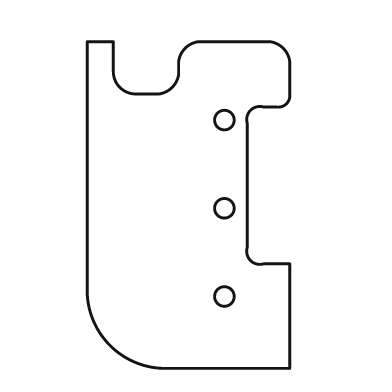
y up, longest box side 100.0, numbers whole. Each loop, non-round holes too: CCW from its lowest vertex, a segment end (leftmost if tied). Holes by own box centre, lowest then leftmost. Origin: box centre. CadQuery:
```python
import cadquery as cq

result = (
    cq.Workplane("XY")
    .moveTo(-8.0, -50.0)
    .lineTo(31.0, -50.0)
    .lineTo(31.0, -18.0)
    .lineTo(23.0, -18.0)
    .threePointArc((19.0, -17.0), (18.0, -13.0))
    .lineTo(18.0, 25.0)
    .threePointArc((19.0, 29.0), (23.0, 30.0))
    .lineTo(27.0, 30.0)
    .threePointArc((30.0, 31.0), (31.0, 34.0))
    .lineTo(31.0, 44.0)
    .threePointArc((29.0, 48.0), (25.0, 50.0))
    .lineTo(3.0, 50.0)
    .threePointArc((-1.0, 48.0), (-3.0, 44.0))
    .lineTo(-3.0, 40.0)
    .threePointArc((-5.0, 36.0), (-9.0, 34.0))
    .lineTo(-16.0, 34.0)
    .threePointArc((-21.0, 36.0), (-23.0, 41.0))
    .lineTo(-23.0, 50.0)
    .lineTo(-31.0, 50.0)
    .lineTo(-31.0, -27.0)
    .threePointArc((-24.0, -43.0), (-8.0, -50.0))
    .close()
    .moveTo(11.0, -28.0)
    .circle(3.0)
    .moveTo(11.0, -1.0)
    .circle(3.0)
    .moveTo(11.0, 26.0)
    .circle(3.0)
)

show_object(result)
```